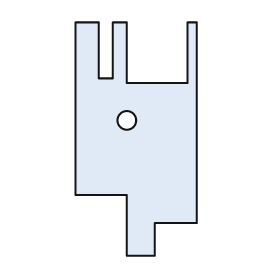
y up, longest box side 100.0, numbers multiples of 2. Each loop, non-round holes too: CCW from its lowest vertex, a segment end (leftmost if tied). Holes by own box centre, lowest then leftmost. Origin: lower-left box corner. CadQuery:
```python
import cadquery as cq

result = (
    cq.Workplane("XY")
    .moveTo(22.0, 0.0)
    .lineTo(34.0, 0.0)
    .lineTo(34.0, 14.0)
    .lineTo(52.0, 14.0)
    .lineTo(52.0, 100.0)
    .lineTo(48.0, 100.0)
    .lineTo(48.0, 74.0)
    .lineTo(22.0, 74.0)
    .lineTo(22.0, 100.0)
    .lineTo(16.0, 100.0)
    .lineTo(16.0, 76.0)
    .lineTo(10.0, 76.0)
    .lineTo(10.0, 100.0)
    .lineTo(0.0, 100.0)
    .lineTo(0.0, 26.0)
    .lineTo(22.0, 26.0)
    .close()
    .moveTo(22.0, 58.0)
    .circle(4.0)
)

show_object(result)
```